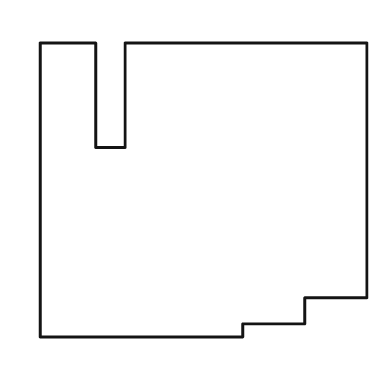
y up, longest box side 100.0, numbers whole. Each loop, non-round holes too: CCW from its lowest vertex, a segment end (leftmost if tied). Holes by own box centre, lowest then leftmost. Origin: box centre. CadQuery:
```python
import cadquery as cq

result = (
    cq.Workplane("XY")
    .moveTo(-50.0, -45.0)
    .lineTo(12.0, -45.0)
    .lineTo(12.0, -41.0)
    .lineTo(31.0, -41.0)
    .lineTo(31.0, -33.0)
    .lineTo(50.0, -33.0)
    .lineTo(50.0, 45.0)
    .lineTo(-24.0, 45.0)
    .lineTo(-24.0, 13.0)
    .lineTo(-33.0, 13.0)
    .lineTo(-33.0, 45.0)
    .lineTo(-50.0, 45.0)
    .close()
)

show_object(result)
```